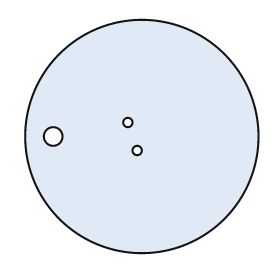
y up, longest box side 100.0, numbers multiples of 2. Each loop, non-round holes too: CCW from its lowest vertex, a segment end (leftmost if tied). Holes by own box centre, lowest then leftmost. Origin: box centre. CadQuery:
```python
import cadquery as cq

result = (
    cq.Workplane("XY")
    .moveTo(0.0, 0.0)
    .circle(50.0)
    .moveTo(-2.0, -6.0)
    .circle(2.0)
    .moveTo(-38.0, 0.0)
    .circle(4.0)
    .moveTo(-6.0, 6.0)
    .circle(2.0)
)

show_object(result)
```